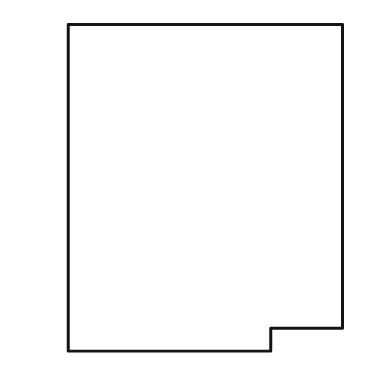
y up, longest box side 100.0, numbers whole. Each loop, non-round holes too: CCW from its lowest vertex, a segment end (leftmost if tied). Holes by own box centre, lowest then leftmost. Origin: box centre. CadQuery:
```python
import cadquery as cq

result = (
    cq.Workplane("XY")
    .moveTo(-42.0, -50.0)
    .lineTo(20.0, -50.0)
    .lineTo(20.0, -43.0)
    .lineTo(42.0, -43.0)
    .lineTo(42.0, 50.0)
    .lineTo(-42.0, 50.0)
    .close()
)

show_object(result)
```